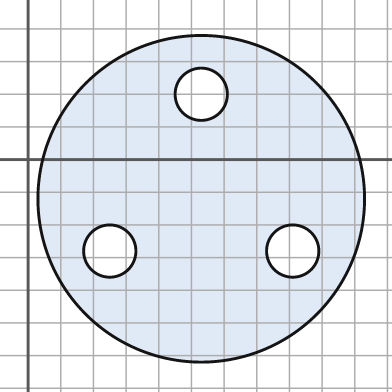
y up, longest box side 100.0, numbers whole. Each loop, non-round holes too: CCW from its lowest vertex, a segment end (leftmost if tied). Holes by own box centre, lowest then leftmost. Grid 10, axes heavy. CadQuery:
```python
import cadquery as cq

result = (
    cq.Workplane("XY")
    .moveTo(53.0, -12.0)
    .circle(50.0)
    .moveTo(25.0, -28.0)
    .circle(8.0)
    .moveTo(81.0, -28.0)
    .circle(8.0)
    .moveTo(53.0, 20.0)
    .circle(8.0)
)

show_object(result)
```